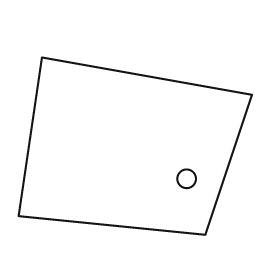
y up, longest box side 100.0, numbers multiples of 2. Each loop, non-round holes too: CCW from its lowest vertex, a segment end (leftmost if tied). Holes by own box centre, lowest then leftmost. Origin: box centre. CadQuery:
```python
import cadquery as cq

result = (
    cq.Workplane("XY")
    .moveTo(30.0, -38.0)
    .lineTo(50.0, 22.0)
    .lineTo(-40.0, 38.0)
    .lineTo(-50.0, -30.0)
    .close()
    .moveTo(22.0, -14.0)
    .circle(4.0)
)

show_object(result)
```